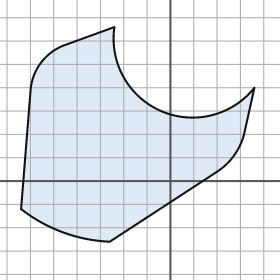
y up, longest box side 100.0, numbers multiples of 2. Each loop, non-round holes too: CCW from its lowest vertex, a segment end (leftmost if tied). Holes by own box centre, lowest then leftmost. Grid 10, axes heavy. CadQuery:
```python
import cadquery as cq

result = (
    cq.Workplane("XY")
    .moveTo(-26.0, -26.0)
    .lineTo(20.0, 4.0)
    .threePointArc((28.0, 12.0), (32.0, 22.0))
    .lineTo(36.0, 40.0)
    .threePointArc((-4.0, 30.0), (-24.0, 66.0))
    .lineTo(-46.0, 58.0)
    .threePointArc((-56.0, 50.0), (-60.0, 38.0))
    .lineTo(-64.0, -12.0)
    .threePointArc((-46.0, -22.0), (-26.0, -26.0))
    .close()
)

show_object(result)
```